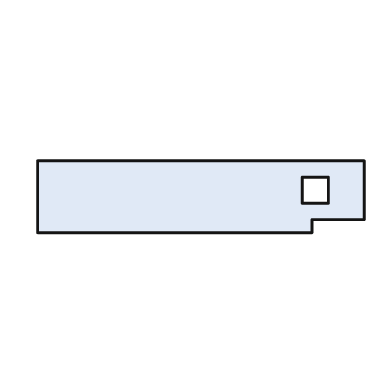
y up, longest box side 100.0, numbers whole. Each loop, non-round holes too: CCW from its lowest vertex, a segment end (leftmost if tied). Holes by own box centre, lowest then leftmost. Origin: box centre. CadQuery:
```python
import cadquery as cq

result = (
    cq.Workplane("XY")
    .moveTo(-50.0, -11.0)
    .lineTo(34.0, -11.0)
    .lineTo(34.0, -7.0)
    .lineTo(50.0, -7.0)
    .lineTo(50.0, 11.0)
    .lineTo(-50.0, 11.0)
    .close()
    .moveTo(31.0, -2.0)
    .lineTo(39.0, -2.0)
    .lineTo(39.0, 6.0)
    .lineTo(31.0, 6.0)
    .close()
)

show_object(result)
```